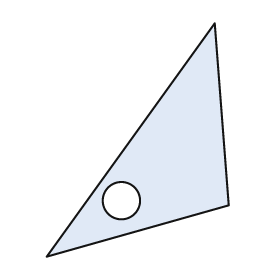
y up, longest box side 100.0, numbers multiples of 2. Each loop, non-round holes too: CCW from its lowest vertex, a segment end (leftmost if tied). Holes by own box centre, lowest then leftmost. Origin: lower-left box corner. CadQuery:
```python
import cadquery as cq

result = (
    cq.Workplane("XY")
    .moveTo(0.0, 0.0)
    .lineTo(78.0, 22.0)
    .lineTo(72.0, 100.0)
    .close()
    .moveTo(32.0, 24.0)
    .circle(8.0)
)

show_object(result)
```